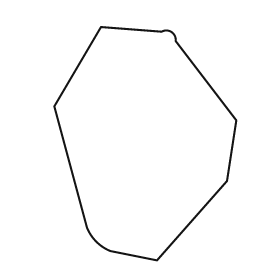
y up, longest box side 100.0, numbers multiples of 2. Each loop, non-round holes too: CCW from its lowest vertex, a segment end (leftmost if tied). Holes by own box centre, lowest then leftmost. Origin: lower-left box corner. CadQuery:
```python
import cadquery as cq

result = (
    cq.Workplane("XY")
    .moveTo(44.0, 0.0)
    .lineTo(74.0, 34.0)
    .lineTo(78.0, 60.0)
    .lineTo(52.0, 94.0)
    .threePointArc((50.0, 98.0), (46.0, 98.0))
    .lineTo(20.0, 100.0)
    .lineTo(0.0, 66.0)
    .lineTo(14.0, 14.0)
    .threePointArc((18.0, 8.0), (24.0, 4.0))
    .close()
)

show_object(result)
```